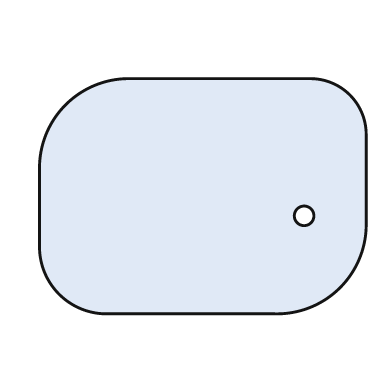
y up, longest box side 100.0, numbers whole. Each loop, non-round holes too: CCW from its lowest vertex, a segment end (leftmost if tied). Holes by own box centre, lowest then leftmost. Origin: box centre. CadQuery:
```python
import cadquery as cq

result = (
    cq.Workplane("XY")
    .moveTo(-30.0, -36.0)
    .lineTo(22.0, -36.0)
    .threePointArc((42.0, -28.0), (50.0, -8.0))
    .lineTo(50.0, 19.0)
    .threePointArc((45.0, 31.0), (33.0, 36.0))
    .lineTo(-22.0, 36.0)
    .threePointArc((-42.0, 28.0), (-50.0, 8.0))
    .lineTo(-50.0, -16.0)
    .threePointArc((-44.0, -30.0), (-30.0, -36.0))
    .close()
    .moveTo(31.0, -6.0)
    .circle(3.0)
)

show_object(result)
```